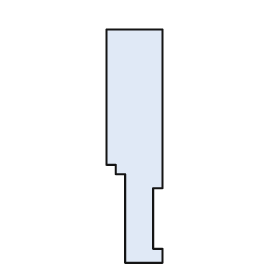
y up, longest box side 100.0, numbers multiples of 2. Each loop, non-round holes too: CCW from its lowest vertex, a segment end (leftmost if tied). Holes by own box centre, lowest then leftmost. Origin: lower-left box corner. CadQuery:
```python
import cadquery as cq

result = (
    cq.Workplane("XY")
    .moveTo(8.0, 0.0)
    .lineTo(24.0, 0.0)
    .lineTo(24.0, 6.0)
    .lineTo(20.0, 6.0)
    .lineTo(20.0, 32.0)
    .lineTo(24.0, 32.0)
    .lineTo(24.0, 100.0)
    .lineTo(0.0, 100.0)
    .lineTo(0.0, 42.0)
    .lineTo(4.0, 42.0)
    .lineTo(4.0, 38.0)
    .lineTo(8.0, 38.0)
    .close()
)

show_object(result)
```